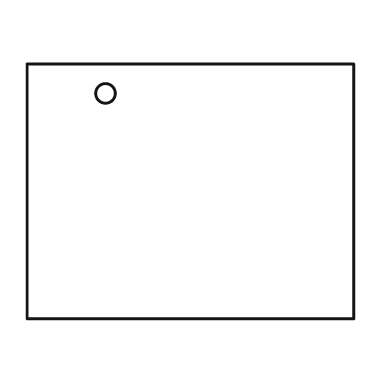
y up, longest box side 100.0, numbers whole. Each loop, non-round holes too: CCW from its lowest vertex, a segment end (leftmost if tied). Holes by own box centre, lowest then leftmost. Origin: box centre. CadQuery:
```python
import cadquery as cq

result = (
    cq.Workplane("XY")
    .moveTo(-50.0, -39.0)
    .lineTo(50.0, -39.0)
    .lineTo(50.0, 39.0)
    .lineTo(-50.0, 39.0)
    .close()
    .moveTo(-26.0, 30.0)
    .circle(3.0)
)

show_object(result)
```